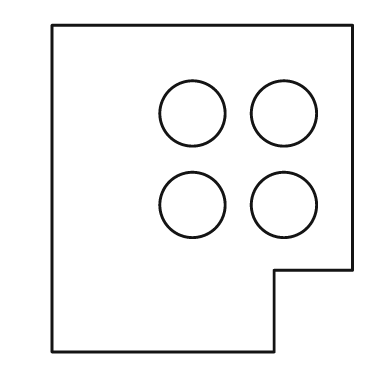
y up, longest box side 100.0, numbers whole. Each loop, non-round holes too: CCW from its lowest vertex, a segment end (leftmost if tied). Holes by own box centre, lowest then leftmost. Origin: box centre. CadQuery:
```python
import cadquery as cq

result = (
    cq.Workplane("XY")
    .moveTo(-46.0, -50.0)
    .lineTo(22.0, -50.0)
    .lineTo(22.0, -25.0)
    .lineTo(46.0, -25.0)
    .lineTo(46.0, 50.0)
    .lineTo(-46.0, 50.0)
    .close()
    .moveTo(-3.0, -5.0)
    .circle(10.0)
    .moveTo(25.0, -5.0)
    .circle(10.0)
    .moveTo(-3.0, 23.0)
    .circle(10.0)
    .moveTo(25.0, 23.0)
    .circle(10.0)
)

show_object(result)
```